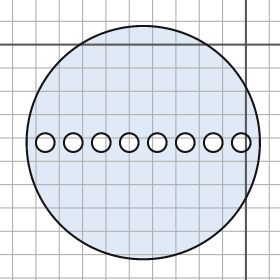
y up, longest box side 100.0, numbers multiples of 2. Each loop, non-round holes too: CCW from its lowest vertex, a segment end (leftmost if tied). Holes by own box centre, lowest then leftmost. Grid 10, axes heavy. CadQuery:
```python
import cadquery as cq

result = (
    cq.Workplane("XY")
    .moveTo(-44.0, -42.0)
    .circle(50.0)
    .moveTo(-86.0, -42.0)
    .circle(4.0)
    .moveTo(-74.0, -42.0)
    .circle(4.0)
    .moveTo(-62.0, -42.0)
    .circle(4.0)
    .moveTo(-50.0, -42.0)
    .circle(4.0)
    .moveTo(-38.0, -42.0)
    .circle(4.0)
    .moveTo(-26.0, -42.0)
    .circle(4.0)
    .moveTo(-14.0, -42.0)
    .circle(4.0)
    .moveTo(-2.0, -42.0)
    .circle(4.0)
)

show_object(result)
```